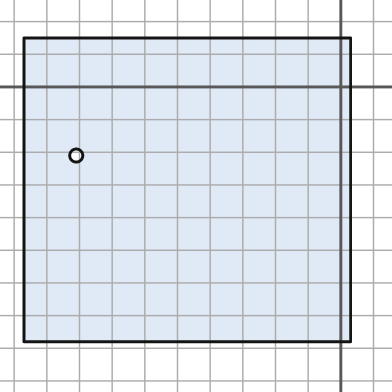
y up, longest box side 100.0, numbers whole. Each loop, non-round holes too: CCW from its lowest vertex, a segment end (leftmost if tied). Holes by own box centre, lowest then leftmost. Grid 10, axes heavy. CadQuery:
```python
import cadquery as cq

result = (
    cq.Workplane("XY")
    .moveTo(-97.0, -78.0)
    .lineTo(3.0, -78.0)
    .lineTo(3.0, 15.0)
    .lineTo(-97.0, 15.0)
    .close()
    .moveTo(-81.0, -21.0)
    .circle(2.0)
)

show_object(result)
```